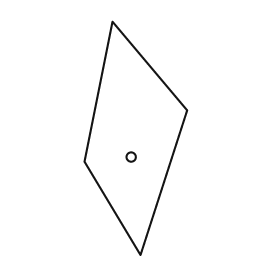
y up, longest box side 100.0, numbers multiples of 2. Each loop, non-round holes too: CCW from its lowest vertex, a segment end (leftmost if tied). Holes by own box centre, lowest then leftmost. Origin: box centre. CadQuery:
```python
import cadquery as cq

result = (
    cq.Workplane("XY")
    .moveTo(2.0, -50.0)
    .lineTo(22.0, 12.0)
    .lineTo(-10.0, 50.0)
    .lineTo(-22.0, -10.0)
    .close()
    .moveTo(-2.0, -8.0)
    .circle(2.0)
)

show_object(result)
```